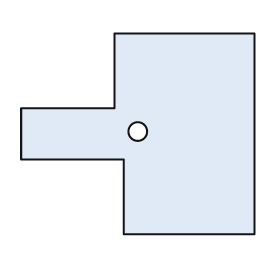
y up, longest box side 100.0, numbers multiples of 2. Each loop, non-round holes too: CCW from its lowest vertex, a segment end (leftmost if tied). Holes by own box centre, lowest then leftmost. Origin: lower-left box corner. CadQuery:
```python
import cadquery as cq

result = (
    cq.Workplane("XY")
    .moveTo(44.0, 0.0)
    .lineTo(100.0, 0.0)
    .lineTo(100.0, 86.0)
    .lineTo(40.0, 86.0)
    .lineTo(40.0, 54.0)
    .lineTo(0.0, 54.0)
    .lineTo(0.0, 32.0)
    .lineTo(44.0, 32.0)
    .close()
    .moveTo(50.0, 44.0)
    .circle(4.0)
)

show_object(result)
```